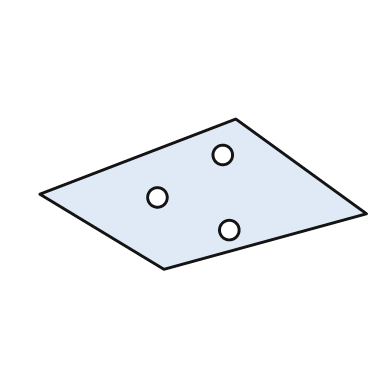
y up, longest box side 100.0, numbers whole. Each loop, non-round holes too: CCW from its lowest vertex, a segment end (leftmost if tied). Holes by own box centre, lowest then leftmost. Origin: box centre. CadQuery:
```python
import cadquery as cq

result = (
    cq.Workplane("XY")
    .moveTo(-12.0, -23.0)
    .lineTo(50.0, -6.0)
    .lineTo(10.0, 23.0)
    .lineTo(-50.0, 0.0)
    .close()
    .moveTo(8.0, -11.0)
    .circle(3.0)
    .moveTo(-14.0, -1.0)
    .circle(3.0)
    .moveTo(6.0, 12.0)
    .circle(3.0)
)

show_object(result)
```